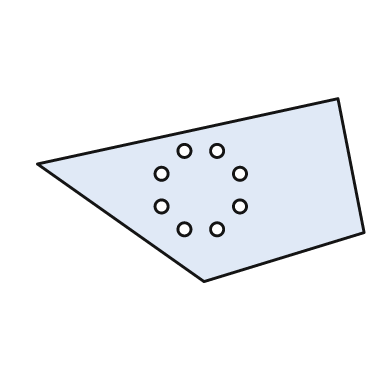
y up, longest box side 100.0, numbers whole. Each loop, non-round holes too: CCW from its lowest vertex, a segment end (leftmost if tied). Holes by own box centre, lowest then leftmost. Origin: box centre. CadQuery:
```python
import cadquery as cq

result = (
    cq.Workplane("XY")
    .moveTo(1.0, -28.0)
    .lineTo(50.0, -13.0)
    .lineTo(42.0, 28.0)
    .lineTo(-50.0, 8.0)
    .close()
    .moveTo(-5.0, -12.0)
    .circle(2.0)
    .moveTo(5.0, -12.0)
    .circle(2.0)
    .moveTo(-12.0, -5.0)
    .circle(2.0)
    .moveTo(12.0, -5.0)
    .circle(2.0)
    .moveTo(-12.0, 5.0)
    .circle(2.0)
    .moveTo(12.0, 5.0)
    .circle(2.0)
    .moveTo(-5.0, 12.0)
    .circle(2.0)
    .moveTo(5.0, 12.0)
    .circle(2.0)
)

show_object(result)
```